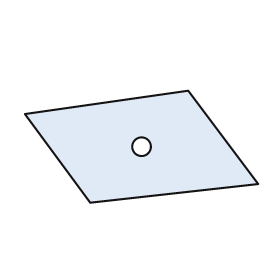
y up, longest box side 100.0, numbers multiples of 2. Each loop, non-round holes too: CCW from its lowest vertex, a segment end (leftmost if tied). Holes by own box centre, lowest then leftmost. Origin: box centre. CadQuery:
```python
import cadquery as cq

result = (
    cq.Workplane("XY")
    .moveTo(-22.0, -24.0)
    .lineTo(50.0, -16.0)
    .lineTo(20.0, 24.0)
    .lineTo(-50.0, 14.0)
    .close()
    .moveTo(0.0, 0.0)
    .circle(4.0)
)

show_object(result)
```